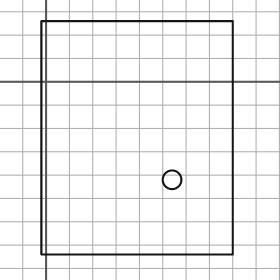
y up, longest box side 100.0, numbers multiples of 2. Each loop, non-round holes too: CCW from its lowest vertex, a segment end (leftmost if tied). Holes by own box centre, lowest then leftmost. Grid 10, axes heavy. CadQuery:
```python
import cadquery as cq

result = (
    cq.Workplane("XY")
    .moveTo(-2.0, -74.0)
    .lineTo(80.0, -74.0)
    .lineTo(80.0, 26.0)
    .lineTo(-2.0, 26.0)
    .close()
    .moveTo(54.0, -42.0)
    .circle(4.0)
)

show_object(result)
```